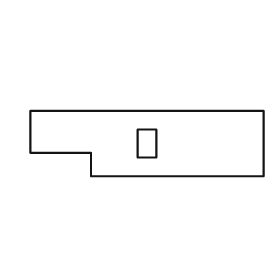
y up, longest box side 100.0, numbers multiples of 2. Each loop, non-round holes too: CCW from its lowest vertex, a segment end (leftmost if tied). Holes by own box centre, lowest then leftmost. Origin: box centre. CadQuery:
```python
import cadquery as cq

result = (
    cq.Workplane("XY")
    .moveTo(-24.0, -14.0)
    .lineTo(50.0, -14.0)
    .lineTo(50.0, 14.0)
    .lineTo(-50.0, 14.0)
    .lineTo(-50.0, -4.0)
    .lineTo(-24.0, -4.0)
    .close()
    .moveTo(-4.0, -6.0)
    .lineTo(4.0, -6.0)
    .lineTo(4.0, 6.0)
    .lineTo(-4.0, 6.0)
    .close()
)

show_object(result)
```